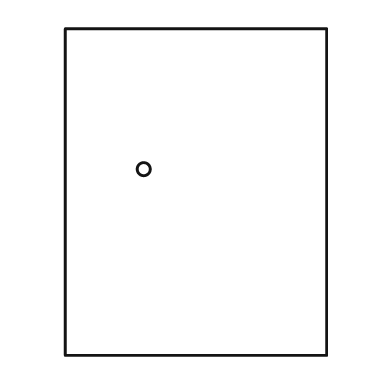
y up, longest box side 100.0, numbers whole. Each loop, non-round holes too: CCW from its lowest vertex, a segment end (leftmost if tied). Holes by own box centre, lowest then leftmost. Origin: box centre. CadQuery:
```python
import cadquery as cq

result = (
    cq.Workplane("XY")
    .moveTo(-40.0, -50.0)
    .lineTo(40.0, -50.0)
    .lineTo(40.0, 50.0)
    .lineTo(-40.0, 50.0)
    .close()
    .moveTo(-16.0, 7.0)
    .circle(2.0)
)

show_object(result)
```